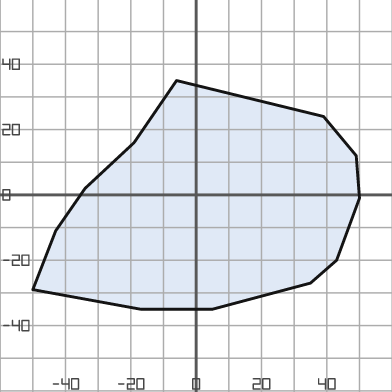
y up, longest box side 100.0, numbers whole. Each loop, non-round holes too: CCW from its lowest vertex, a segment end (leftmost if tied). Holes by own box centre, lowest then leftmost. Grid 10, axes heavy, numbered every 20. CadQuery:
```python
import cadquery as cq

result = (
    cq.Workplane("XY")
    .moveTo(-17.0, -35.0)
    .lineTo(5.0, -35.0)
    .lineTo(35.0, -27.0)
    .lineTo(43.0, -20.0)
    .lineTo(50.0, -1.0)
    .lineTo(49.0, 12.0)
    .lineTo(39.0, 24.0)
    .lineTo(-6.0, 35.0)
    .lineTo(-19.0, 16.0)
    .lineTo(-34.0, 2.0)
    .lineTo(-43.0, -11.0)
    .lineTo(-50.0, -29.0)
    .close()
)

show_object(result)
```